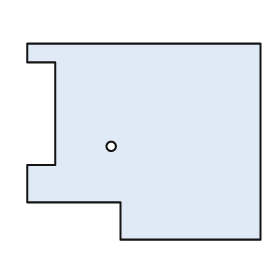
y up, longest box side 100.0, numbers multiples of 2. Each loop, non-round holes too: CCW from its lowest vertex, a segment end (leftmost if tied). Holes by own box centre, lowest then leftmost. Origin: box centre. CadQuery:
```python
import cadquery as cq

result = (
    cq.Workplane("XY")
    .moveTo(-10.0, -42.0)
    .lineTo(50.0, -42.0)
    .lineTo(50.0, 42.0)
    .lineTo(-50.0, 42.0)
    .lineTo(-50.0, 34.0)
    .lineTo(-38.0, 34.0)
    .lineTo(-38.0, -10.0)
    .lineTo(-50.0, -10.0)
    .lineTo(-50.0, -26.0)
    .lineTo(-10.0, -26.0)
    .close()
    .moveTo(-14.0, -2.0)
    .circle(2.0)
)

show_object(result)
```